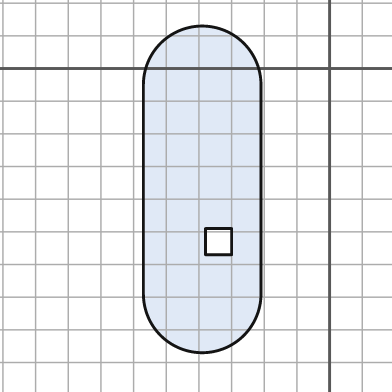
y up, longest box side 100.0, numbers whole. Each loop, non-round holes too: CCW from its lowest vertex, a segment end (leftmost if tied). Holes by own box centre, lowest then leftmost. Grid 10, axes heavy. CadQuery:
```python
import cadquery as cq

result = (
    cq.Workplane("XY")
    .moveTo(-57.0, -69.0)
    .threePointArc((-39.0, -87.0), (-21.0, -69.0))
    .lineTo(-21.0, -5.0)
    .threePointArc((-39.0, 13.0), (-57.0, -5.0))
    .close()
    .moveTo(-38.0, -57.0)
    .lineTo(-30.0, -57.0)
    .lineTo(-30.0, -49.0)
    .lineTo(-38.0, -49.0)
    .close()
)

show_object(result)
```